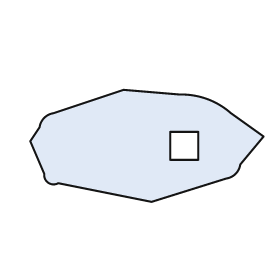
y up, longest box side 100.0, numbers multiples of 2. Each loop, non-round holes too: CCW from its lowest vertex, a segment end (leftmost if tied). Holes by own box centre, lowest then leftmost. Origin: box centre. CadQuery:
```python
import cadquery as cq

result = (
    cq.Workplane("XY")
    .moveTo(2.0, -24.0)
    .lineTo(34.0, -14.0)
    .threePointArc((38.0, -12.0), (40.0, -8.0))
    .lineTo(50.0, 4.0)
    .lineTo(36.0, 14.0)
    .threePointArc((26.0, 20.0), (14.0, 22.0))
    .lineTo(-10.0, 24.0)
    .lineTo(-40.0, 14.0)
    .threePointArc((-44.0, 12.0), (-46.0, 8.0))
    .lineTo(-50.0, 2.0)
    .lineTo(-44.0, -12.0)
    .threePointArc((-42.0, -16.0), (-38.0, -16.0))
    .close()
    .moveTo(10.0, -6.0)
    .lineTo(22.0, -6.0)
    .lineTo(22.0, 6.0)
    .lineTo(10.0, 6.0)
    .close()
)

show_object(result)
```